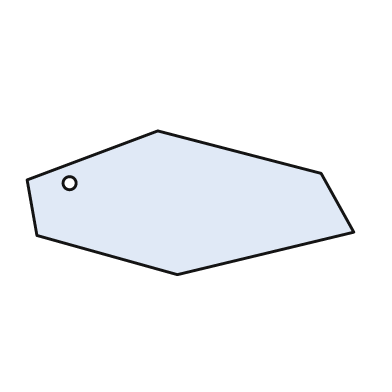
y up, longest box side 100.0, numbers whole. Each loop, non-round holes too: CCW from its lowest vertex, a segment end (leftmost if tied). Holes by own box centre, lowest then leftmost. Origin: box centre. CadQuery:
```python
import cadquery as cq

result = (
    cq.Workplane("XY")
    .moveTo(-4.0, -22.0)
    .lineTo(50.0, -9.0)
    .lineTo(40.0, 9.0)
    .lineTo(-10.0, 22.0)
    .lineTo(-50.0, 7.0)
    .lineTo(-47.0, -10.0)
    .close()
    .moveTo(-37.0, 6.0)
    .circle(2.0)
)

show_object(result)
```